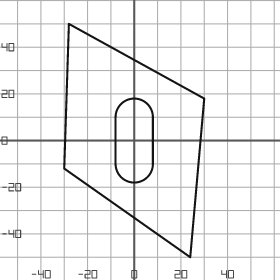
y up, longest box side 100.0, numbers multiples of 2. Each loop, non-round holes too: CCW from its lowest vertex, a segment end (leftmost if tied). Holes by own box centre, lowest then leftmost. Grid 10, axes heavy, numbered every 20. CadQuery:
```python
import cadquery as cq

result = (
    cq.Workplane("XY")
    .moveTo(24.0, -50.0)
    .lineTo(30.0, 18.0)
    .lineTo(-28.0, 50.0)
    .lineTo(-30.0, -12.0)
    .close()
    .moveTo(-8.0, -10.0)
    .threePointArc((0.0, -18.0), (8.0, -10.0))
    .lineTo(8.0, 10.0)
    .threePointArc((0.0, 18.0), (-8.0, 10.0))
    .close()
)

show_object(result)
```